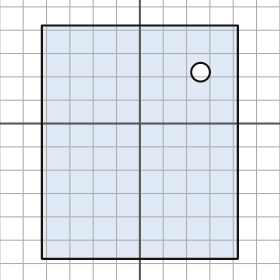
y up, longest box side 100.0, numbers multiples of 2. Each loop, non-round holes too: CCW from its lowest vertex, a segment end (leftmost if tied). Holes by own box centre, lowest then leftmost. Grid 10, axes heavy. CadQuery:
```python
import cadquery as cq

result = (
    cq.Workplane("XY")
    .moveTo(-42.0, -58.0)
    .lineTo(42.0, -58.0)
    .lineTo(42.0, 42.0)
    .lineTo(-42.0, 42.0)
    .close()
    .moveTo(26.0, 22.0)
    .circle(4.0)
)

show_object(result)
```